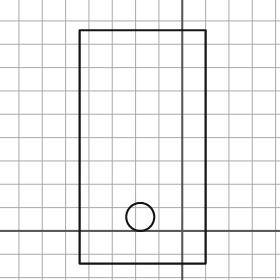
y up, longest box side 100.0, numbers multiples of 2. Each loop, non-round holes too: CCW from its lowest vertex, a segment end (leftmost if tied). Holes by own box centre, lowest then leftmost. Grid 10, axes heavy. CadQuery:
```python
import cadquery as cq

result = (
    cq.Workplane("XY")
    .moveTo(-44.0, -14.0)
    .lineTo(10.0, -14.0)
    .lineTo(10.0, 86.0)
    .lineTo(-44.0, 86.0)
    .close()
    .moveTo(-18.0, 6.0)
    .circle(6.0)
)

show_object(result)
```